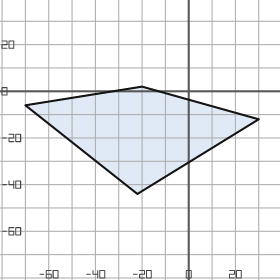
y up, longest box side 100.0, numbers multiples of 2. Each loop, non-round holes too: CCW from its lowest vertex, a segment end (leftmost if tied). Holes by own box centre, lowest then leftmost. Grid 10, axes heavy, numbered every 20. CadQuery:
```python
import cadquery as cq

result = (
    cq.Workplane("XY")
    .moveTo(-22.0, -44.0)
    .lineTo(30.0, -12.0)
    .lineTo(-20.0, 2.0)
    .lineTo(-70.0, -6.0)
    .close()
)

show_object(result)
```